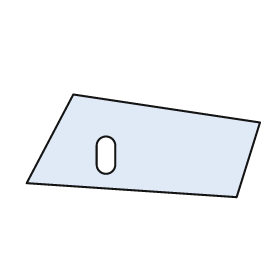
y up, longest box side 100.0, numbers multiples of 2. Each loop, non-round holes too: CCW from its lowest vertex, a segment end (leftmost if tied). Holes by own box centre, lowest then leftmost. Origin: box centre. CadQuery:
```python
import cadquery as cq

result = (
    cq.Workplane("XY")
    .moveTo(40.0, -22.0)
    .lineTo(50.0, 10.0)
    .lineTo(-30.0, 22.0)
    .lineTo(-50.0, -16.0)
    .close()
    .moveTo(-20.0, -8.0)
    .threePointArc((-16.0, -12.0), (-12.0, -8.0))
    .lineTo(-12.0, 0.0)
    .threePointArc((-16.0, 4.0), (-20.0, 0.0))
    .close()
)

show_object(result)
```